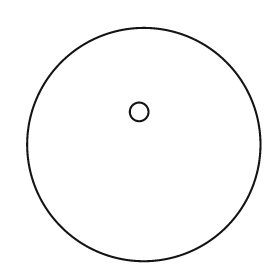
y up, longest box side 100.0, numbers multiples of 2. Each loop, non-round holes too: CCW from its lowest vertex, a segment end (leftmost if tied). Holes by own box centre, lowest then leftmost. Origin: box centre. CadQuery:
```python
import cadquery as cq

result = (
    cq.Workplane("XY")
    .moveTo(0.0, 0.0)
    .circle(50.0)
    .moveTo(-2.0, 14.0)
    .circle(4.0)
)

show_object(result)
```